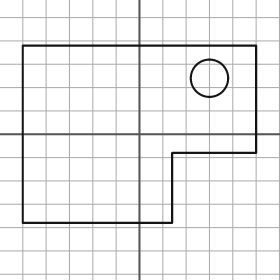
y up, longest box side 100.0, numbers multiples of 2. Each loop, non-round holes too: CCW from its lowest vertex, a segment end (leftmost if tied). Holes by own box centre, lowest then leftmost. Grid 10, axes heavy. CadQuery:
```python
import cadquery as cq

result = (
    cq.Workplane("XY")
    .moveTo(-50.0, -38.0)
    .lineTo(14.0, -38.0)
    .lineTo(14.0, -8.0)
    .lineTo(50.0, -8.0)
    .lineTo(50.0, 38.0)
    .lineTo(-50.0, 38.0)
    .close()
    .moveTo(30.0, 24.0)
    .circle(8.0)
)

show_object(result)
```